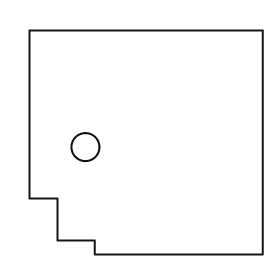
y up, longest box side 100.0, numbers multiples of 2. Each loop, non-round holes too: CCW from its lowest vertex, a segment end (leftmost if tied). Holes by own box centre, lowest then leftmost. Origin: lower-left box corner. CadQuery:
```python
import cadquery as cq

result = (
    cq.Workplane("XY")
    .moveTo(28.0, 0.0)
    .lineTo(100.0, 0.0)
    .lineTo(100.0, 96.0)
    .lineTo(0.0, 96.0)
    .lineTo(0.0, 24.0)
    .lineTo(12.0, 24.0)
    .lineTo(12.0, 6.0)
    .lineTo(28.0, 6.0)
    .close()
    .moveTo(24.0, 46.0)
    .circle(6.0)
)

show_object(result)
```